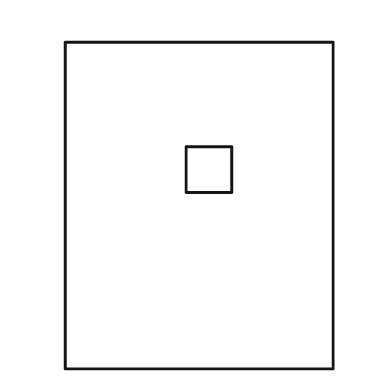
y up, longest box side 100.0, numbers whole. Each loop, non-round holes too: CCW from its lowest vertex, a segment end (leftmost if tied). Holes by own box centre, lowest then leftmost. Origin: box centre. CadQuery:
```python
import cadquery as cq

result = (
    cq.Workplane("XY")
    .moveTo(-41.0, -50.0)
    .lineTo(41.0, -50.0)
    .lineTo(41.0, 50.0)
    .lineTo(-41.0, 50.0)
    .close()
    .moveTo(-4.0, 4.0)
    .lineTo(10.0, 4.0)
    .lineTo(10.0, 18.0)
    .lineTo(-4.0, 18.0)
    .close()
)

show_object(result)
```